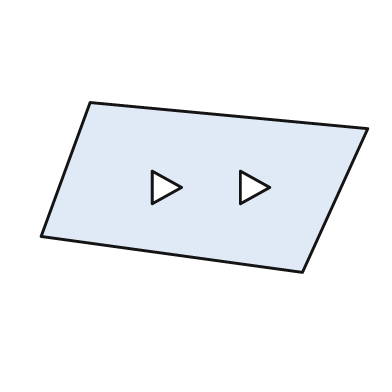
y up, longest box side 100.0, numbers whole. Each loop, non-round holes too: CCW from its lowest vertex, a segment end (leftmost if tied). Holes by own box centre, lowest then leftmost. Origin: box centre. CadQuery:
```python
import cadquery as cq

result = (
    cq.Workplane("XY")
    .moveTo(30.0, -26.0)
    .lineTo(50.0, 18.0)
    .lineTo(-35.0, 26.0)
    .lineTo(-50.0, -15.0)
    .close()
    .moveTo(-16.0, -5.0)
    .lineTo(-7.0, 0.0)
    .lineTo(-16.0, 5.0)
    .close()
    .moveTo(11.0, -5.0)
    .lineTo(20.0, 0.0)
    .lineTo(11.0, 5.0)
    .close()
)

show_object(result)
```